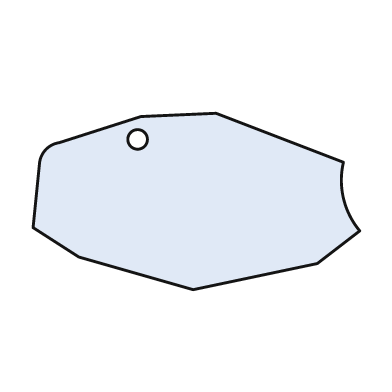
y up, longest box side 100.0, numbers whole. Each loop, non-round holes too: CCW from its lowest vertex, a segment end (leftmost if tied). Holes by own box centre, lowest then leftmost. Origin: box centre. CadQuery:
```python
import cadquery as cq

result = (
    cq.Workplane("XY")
    .moveTo(-1.0, -27.0)
    .lineTo(37.0, -19.0)
    .lineTo(50.0, -9.0)
    .threePointArc((45.0, 1.0), (45.0, 12.0))
    .lineTo(6.0, 27.0)
    .lineTo(-17.0, 26.0)
    .lineTo(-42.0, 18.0)
    .threePointArc((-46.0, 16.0), (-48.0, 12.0))
    .lineTo(-50.0, -8.0)
    .lineTo(-36.0, -17.0)
    .close()
    .moveTo(-18.0, 19.0)
    .circle(3.0)
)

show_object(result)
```